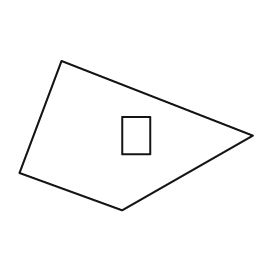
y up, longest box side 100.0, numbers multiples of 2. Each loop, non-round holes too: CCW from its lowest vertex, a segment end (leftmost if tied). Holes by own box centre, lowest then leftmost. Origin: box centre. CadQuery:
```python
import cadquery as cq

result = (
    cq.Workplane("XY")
    .moveTo(-6.0, -32.0)
    .lineTo(50.0, 0.0)
    .lineTo(-32.0, 32.0)
    .lineTo(-50.0, -16.0)
    .close()
    .moveTo(-6.0, -8.0)
    .lineTo(6.0, -8.0)
    .lineTo(6.0, 8.0)
    .lineTo(-6.0, 8.0)
    .close()
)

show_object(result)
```